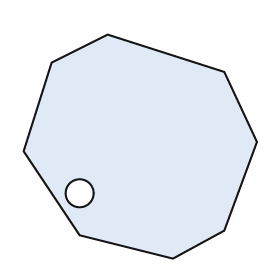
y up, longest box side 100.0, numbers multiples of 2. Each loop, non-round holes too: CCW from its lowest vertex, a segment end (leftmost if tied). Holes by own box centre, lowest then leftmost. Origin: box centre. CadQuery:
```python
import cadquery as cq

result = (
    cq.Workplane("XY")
    .moveTo(14.0, -48.0)
    .lineTo(36.0, -36.0)
    .lineTo(50.0, 2.0)
    .lineTo(36.0, 32.0)
    .lineTo(-14.0, 48.0)
    .lineTo(-38.0, 36.0)
    .lineTo(-50.0, -2.0)
    .lineTo(-26.0, -38.0)
    .close()
    .moveTo(-26.0, -20.0)
    .circle(6.0)
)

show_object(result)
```